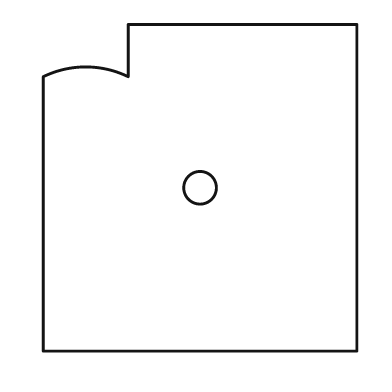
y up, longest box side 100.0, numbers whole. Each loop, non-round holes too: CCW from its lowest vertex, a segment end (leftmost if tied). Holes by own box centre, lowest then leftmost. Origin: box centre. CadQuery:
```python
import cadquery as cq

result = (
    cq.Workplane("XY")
    .moveTo(-48.0, -50.0)
    .lineTo(48.0, -50.0)
    .lineTo(48.0, 50.0)
    .lineTo(-22.0, 50.0)
    .lineTo(-22.0, 34.0)
    .threePointArc((-35.0, 37.0), (-48.0, 34.0))
    .close()
    .moveTo(0.0, 0.0)
    .circle(5.0)
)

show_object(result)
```